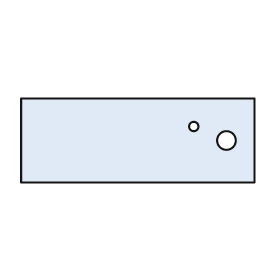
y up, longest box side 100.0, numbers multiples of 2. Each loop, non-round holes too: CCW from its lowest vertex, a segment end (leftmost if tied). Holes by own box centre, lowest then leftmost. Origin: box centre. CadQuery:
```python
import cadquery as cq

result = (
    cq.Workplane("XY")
    .moveTo(-50.0, -18.0)
    .lineTo(50.0, -18.0)
    .lineTo(50.0, 18.0)
    .lineTo(-50.0, 18.0)
    .close()
    .moveTo(38.0, 0.0)
    .circle(4.0)
    .moveTo(24.0, 6.0)
    .circle(2.0)
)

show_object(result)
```